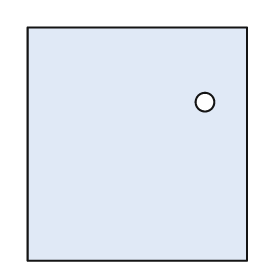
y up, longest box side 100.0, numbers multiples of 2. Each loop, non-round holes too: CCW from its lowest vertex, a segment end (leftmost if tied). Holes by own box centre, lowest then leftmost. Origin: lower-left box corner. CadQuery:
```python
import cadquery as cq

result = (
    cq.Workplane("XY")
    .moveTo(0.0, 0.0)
    .lineTo(94.0, 0.0)
    .lineTo(94.0, 100.0)
    .lineTo(0.0, 100.0)
    .close()
    .moveTo(76.0, 68.0)
    .circle(4.0)
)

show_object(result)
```